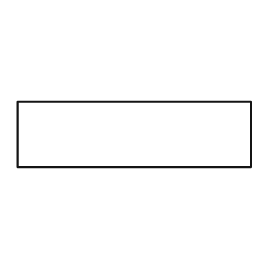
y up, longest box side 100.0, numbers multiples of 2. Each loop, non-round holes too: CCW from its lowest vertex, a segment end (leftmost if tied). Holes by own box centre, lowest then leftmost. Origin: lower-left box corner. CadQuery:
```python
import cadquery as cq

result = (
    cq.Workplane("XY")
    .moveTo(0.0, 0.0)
    .lineTo(100.0, 0.0)
    .lineTo(100.0, 28.0)
    .lineTo(0.0, 28.0)
    .close()
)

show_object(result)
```